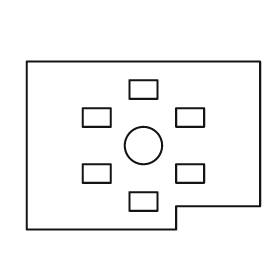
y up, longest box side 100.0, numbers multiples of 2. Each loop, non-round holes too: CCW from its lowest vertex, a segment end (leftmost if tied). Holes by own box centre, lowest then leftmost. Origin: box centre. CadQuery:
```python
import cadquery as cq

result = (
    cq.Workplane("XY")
    .moveTo(-50.0, -36.0)
    .lineTo(14.0, -36.0)
    .lineTo(14.0, -26.0)
    .lineTo(50.0, -26.0)
    .lineTo(50.0, 36.0)
    .lineTo(-50.0, 36.0)
    .close()
    .moveTo(-6.0, -28.0)
    .lineTo(6.0, -28.0)
    .lineTo(6.0, -20.0)
    .lineTo(-6.0, -20.0)
    .close()
    .moveTo(-26.0, -16.0)
    .lineTo(-14.0, -16.0)
    .lineTo(-14.0, -8.0)
    .lineTo(-26.0, -8.0)
    .close()
    .moveTo(14.0, -16.0)
    .lineTo(26.0, -16.0)
    .lineTo(26.0, -8.0)
    .lineTo(14.0, -8.0)
    .close()
    .moveTo(0.0, 0.0)
    .circle(8.0)
    .moveTo(-26.0, 8.0)
    .lineTo(-14.0, 8.0)
    .lineTo(-14.0, 16.0)
    .lineTo(-26.0, 16.0)
    .close()
    .moveTo(14.0, 8.0)
    .lineTo(26.0, 8.0)
    .lineTo(26.0, 16.0)
    .lineTo(14.0, 16.0)
    .close()
    .moveTo(-6.0, 20.0)
    .lineTo(6.0, 20.0)
    .lineTo(6.0, 28.0)
    .lineTo(-6.0, 28.0)
    .close()
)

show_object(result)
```